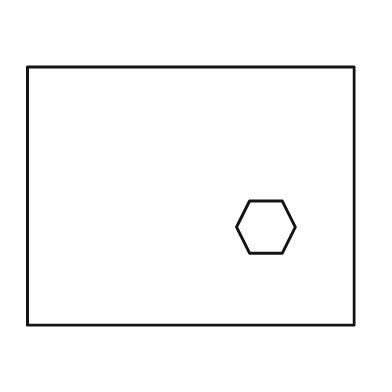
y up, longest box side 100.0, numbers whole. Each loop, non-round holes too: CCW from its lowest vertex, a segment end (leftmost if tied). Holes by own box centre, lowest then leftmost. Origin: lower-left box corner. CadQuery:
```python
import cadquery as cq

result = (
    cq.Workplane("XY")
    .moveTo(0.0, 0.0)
    .lineTo(100.0, 0.0)
    .lineTo(100.0, 79.0)
    .lineTo(0.0, 79.0)
    .close()
    .moveTo(68.0, 22.0)
    .lineTo(78.0, 22.0)
    .lineTo(82.0, 30.0)
    .lineTo(78.0, 38.0)
    .lineTo(68.0, 38.0)
    .lineTo(64.0, 30.0)
    .close()
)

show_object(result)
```